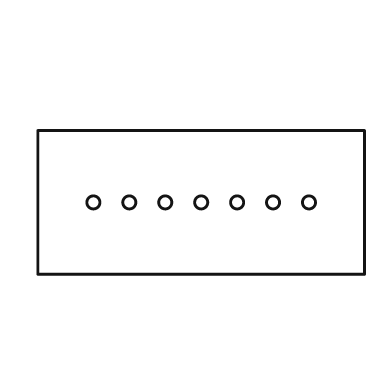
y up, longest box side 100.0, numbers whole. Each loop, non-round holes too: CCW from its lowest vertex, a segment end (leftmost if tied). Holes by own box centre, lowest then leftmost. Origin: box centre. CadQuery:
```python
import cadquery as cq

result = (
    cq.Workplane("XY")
    .moveTo(-50.0, -22.0)
    .lineTo(50.0, -22.0)
    .lineTo(50.0, 22.0)
    .lineTo(-50.0, 22.0)
    .close()
    .moveTo(-33.0, 0.0)
    .circle(2.0)
    .moveTo(-22.0, 0.0)
    .circle(2.0)
    .moveTo(-11.0, 0.0)
    .circle(2.0)
    .moveTo(0.0, 0.0)
    .circle(2.0)
    .moveTo(11.0, 0.0)
    .circle(2.0)
    .moveTo(22.0, 0.0)
    .circle(2.0)
    .moveTo(33.0, 0.0)
    .circle(2.0)
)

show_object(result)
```